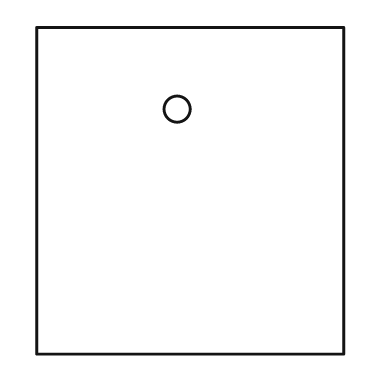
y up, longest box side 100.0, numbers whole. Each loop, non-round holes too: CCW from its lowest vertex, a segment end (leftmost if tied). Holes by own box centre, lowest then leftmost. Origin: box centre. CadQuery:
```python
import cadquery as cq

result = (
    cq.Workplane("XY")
    .moveTo(-47.0, -50.0)
    .lineTo(47.0, -50.0)
    .lineTo(47.0, 50.0)
    .lineTo(-47.0, 50.0)
    .close()
    .moveTo(-4.0, 25.0)
    .circle(4.0)
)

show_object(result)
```